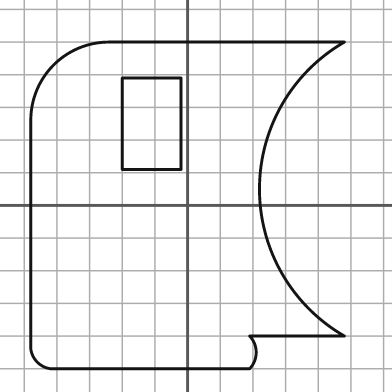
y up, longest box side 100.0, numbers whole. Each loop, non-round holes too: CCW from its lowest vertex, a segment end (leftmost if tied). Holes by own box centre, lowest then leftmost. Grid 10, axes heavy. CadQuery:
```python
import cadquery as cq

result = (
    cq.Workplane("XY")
    .moveTo(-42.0, -50.0)
    .lineTo(19.0, -50.0)
    .threePointArc((21.0, -45.0), (19.0, -40.0))
    .lineTo(48.0, -40.0)
    .threePointArc((22.0, 5.0), (48.0, 50.0))
    .lineTo(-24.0, 50.0)
    .threePointArc((-41.0, 43.0), (-48.0, 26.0))
    .lineTo(-48.0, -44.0)
    .threePointArc((-46.0, -48.0), (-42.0, -50.0))
    .close()
    .moveTo(-20.0, 11.0)
    .lineTo(-2.0, 11.0)
    .lineTo(-2.0, 39.0)
    .lineTo(-20.0, 39.0)
    .close()
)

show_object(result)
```